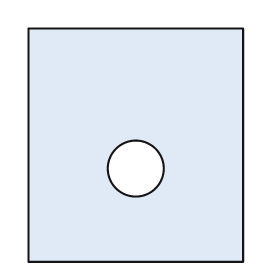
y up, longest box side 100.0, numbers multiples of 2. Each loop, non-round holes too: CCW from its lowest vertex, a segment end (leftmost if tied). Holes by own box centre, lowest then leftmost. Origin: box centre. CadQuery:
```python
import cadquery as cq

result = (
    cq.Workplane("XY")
    .moveTo(-46.0, -50.0)
    .lineTo(46.0, -50.0)
    .lineTo(46.0, 50.0)
    .lineTo(-46.0, 50.0)
    .close()
    .moveTo(0.0, -10.0)
    .circle(12.0)
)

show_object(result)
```